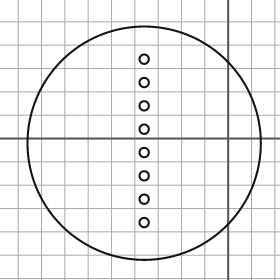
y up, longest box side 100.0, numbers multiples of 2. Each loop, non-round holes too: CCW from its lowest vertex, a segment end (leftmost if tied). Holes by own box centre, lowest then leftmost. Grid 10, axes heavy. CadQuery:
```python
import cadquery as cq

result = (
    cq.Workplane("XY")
    .moveTo(-36.0, -2.0)
    .circle(50.0)
    .moveTo(-36.0, -36.0)
    .circle(2.0)
    .moveTo(-36.0, -26.0)
    .circle(2.0)
    .moveTo(-36.0, -16.0)
    .circle(2.0)
    .moveTo(-36.0, -6.0)
    .circle(2.0)
    .moveTo(-36.0, 4.0)
    .circle(2.0)
    .moveTo(-36.0, 14.0)
    .circle(2.0)
    .moveTo(-36.0, 24.0)
    .circle(2.0)
    .moveTo(-36.0, 34.0)
    .circle(2.0)
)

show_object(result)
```